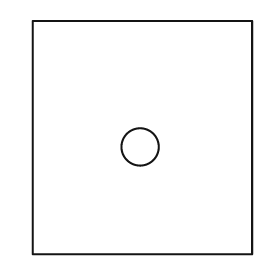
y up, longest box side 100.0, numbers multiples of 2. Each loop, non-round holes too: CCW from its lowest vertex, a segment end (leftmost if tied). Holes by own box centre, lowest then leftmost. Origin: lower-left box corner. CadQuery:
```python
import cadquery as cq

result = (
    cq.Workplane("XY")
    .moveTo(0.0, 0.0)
    .lineTo(94.0, 0.0)
    .lineTo(94.0, 100.0)
    .lineTo(0.0, 100.0)
    .close()
    .moveTo(46.0, 46.0)
    .circle(8.0)
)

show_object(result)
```